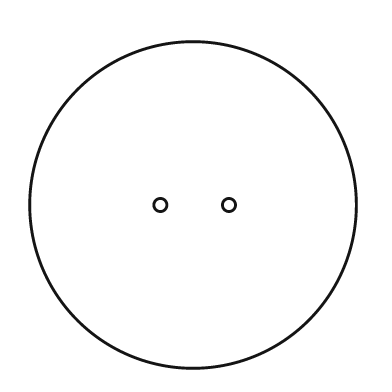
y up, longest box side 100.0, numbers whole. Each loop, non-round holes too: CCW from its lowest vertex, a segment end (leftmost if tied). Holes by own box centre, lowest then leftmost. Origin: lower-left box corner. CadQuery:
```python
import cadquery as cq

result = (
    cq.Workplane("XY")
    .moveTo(50.0, 50.0)
    .circle(50.0)
    .moveTo(40.0, 50.0)
    .circle(2.0)
    .moveTo(61.0, 50.0)
    .circle(2.0)
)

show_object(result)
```